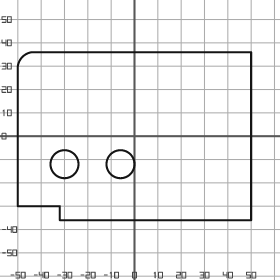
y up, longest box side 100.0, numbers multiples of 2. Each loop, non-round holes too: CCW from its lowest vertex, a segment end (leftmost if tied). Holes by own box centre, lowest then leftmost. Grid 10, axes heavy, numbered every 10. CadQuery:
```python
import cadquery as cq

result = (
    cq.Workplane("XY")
    .moveTo(-32.0, -36.0)
    .lineTo(50.0, -36.0)
    .lineTo(50.0, 36.0)
    .lineTo(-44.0, 36.0)
    .threePointArc((-48.0, 34.0), (-50.0, 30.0))
    .lineTo(-50.0, -30.0)
    .lineTo(-32.0, -30.0)
    .close()
    .moveTo(-30.0, -12.0)
    .circle(6.0)
    .moveTo(-6.0, -12.0)
    .circle(6.0)
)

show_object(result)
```